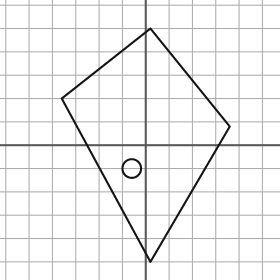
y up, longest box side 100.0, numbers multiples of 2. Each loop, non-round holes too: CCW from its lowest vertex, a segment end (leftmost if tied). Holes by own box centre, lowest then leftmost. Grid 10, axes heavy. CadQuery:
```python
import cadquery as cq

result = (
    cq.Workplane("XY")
    .moveTo(2.0, -50.0)
    .lineTo(36.0, 8.0)
    .lineTo(2.0, 50.0)
    .lineTo(-36.0, 20.0)
    .close()
    .moveTo(-6.0, -10.0)
    .circle(4.0)
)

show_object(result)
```